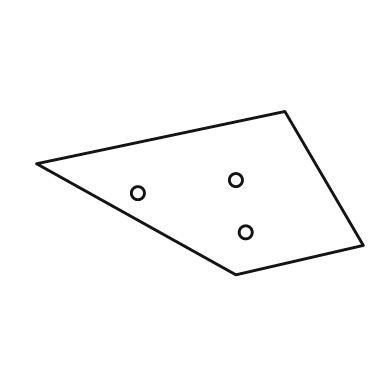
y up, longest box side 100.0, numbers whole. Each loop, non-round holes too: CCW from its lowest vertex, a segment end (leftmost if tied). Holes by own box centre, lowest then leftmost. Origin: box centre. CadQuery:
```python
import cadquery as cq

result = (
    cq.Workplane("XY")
    .moveTo(11.0, -25.0)
    .lineTo(50.0, -16.0)
    .lineTo(26.0, 25.0)
    .lineTo(-50.0, 9.0)
    .close()
    .moveTo(14.0, -12.0)
    .circle(2.0)
    .moveTo(-19.0, 0.0)
    .circle(2.0)
    .moveTo(11.0, 4.0)
    .circle(2.0)
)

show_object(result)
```